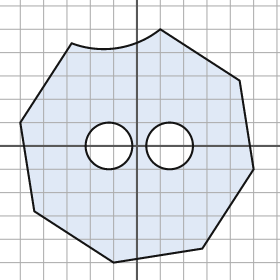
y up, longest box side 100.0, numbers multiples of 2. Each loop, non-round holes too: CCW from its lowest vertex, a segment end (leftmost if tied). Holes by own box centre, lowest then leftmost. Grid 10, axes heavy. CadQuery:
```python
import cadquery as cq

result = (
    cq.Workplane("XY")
    .moveTo(-10.0, -50.0)
    .lineTo(28.0, -44.0)
    .lineTo(50.0, -10.0)
    .lineTo(44.0, 28.0)
    .lineTo(10.0, 50.0)
    .threePointArc((-8.0, 42.0), (-28.0, 44.0))
    .lineTo(-50.0, 10.0)
    .lineTo(-44.0, -28.0)
    .close()
    .moveTo(-12.0, 0.0)
    .circle(10.0)
    .moveTo(14.0, 0.0)
    .circle(10.0)
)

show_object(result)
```